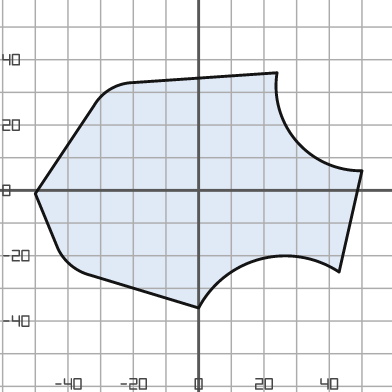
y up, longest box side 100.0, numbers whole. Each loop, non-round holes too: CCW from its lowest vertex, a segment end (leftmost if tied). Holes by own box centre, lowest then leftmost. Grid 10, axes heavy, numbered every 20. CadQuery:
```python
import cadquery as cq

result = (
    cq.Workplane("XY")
    .moveTo(0.0, -36.0)
    .threePointArc((19.0, -21.0), (43.0, -25.0))
    .lineTo(50.0, 6.0)
    .threePointArc((30.0, 15.0), (24.0, 36.0))
    .lineTo(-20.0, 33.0)
    .threePointArc((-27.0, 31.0), (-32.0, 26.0))
    .lineTo(-50.0, -1.0)
    .lineTo(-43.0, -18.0)
    .threePointArc((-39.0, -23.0), (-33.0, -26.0))
    .close()
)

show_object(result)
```